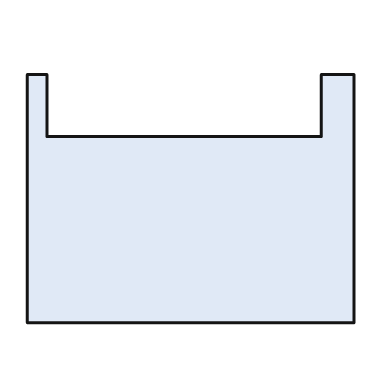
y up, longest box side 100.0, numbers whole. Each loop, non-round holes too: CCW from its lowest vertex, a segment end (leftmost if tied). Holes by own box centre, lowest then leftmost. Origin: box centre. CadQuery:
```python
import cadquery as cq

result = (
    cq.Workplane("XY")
    .moveTo(-50.0, -38.0)
    .lineTo(50.0, -38.0)
    .lineTo(50.0, 38.0)
    .lineTo(40.0, 38.0)
    .lineTo(40.0, 19.0)
    .lineTo(-44.0, 19.0)
    .lineTo(-44.0, 38.0)
    .lineTo(-50.0, 38.0)
    .close()
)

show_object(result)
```